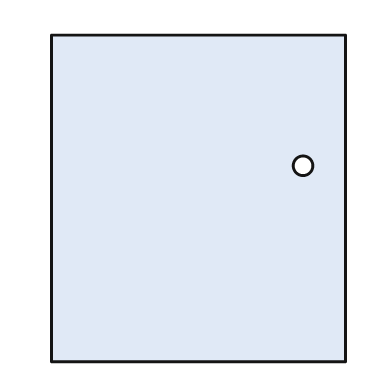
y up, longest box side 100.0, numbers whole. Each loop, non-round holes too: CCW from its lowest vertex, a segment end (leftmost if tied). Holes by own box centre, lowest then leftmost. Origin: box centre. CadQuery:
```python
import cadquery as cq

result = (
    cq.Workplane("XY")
    .moveTo(-45.0, -50.0)
    .lineTo(45.0, -50.0)
    .lineTo(45.0, 50.0)
    .lineTo(-45.0, 50.0)
    .close()
    .moveTo(32.0, 10.0)
    .circle(3.0)
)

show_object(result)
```